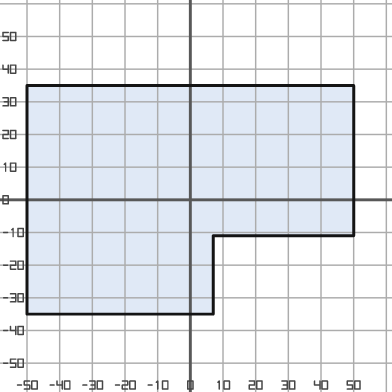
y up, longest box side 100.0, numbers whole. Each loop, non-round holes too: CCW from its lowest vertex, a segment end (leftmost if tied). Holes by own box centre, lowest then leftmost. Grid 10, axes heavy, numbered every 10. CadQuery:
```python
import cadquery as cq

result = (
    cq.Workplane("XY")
    .moveTo(-50.0, -35.0)
    .lineTo(7.0, -35.0)
    .lineTo(7.0, -11.0)
    .lineTo(50.0, -11.0)
    .lineTo(50.0, 35.0)
    .lineTo(-50.0, 35.0)
    .close()
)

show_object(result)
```